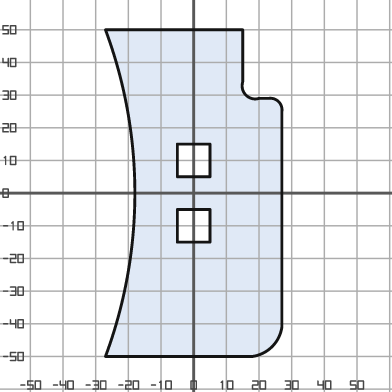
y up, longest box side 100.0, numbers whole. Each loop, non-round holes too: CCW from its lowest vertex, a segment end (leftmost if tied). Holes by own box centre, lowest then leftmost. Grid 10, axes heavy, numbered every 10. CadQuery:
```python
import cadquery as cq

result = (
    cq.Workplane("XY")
    .moveTo(-27.0, -50.0)
    .lineTo(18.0, -50.0)
    .threePointArc((24.0, -47.0), (27.0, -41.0))
    .lineTo(27.0, 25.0)
    .threePointArc((26.0, 28.0), (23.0, 29.0))
    .lineTo(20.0, 29.0)
    .threePointArc((16.0, 30.0), (15.0, 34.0))
    .lineTo(15.0, 50.0)
    .lineTo(-27.0, 50.0)
    .threePointArc((-18.0, 0.0), (-27.0, -50.0))
    .close()
    .moveTo(-5.0, -15.0)
    .lineTo(5.0, -15.0)
    .lineTo(5.0, -5.0)
    .lineTo(-5.0, -5.0)
    .close()
    .moveTo(-5.0, 5.0)
    .lineTo(5.0, 5.0)
    .lineTo(5.0, 15.0)
    .lineTo(-5.0, 15.0)
    .close()
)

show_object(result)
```